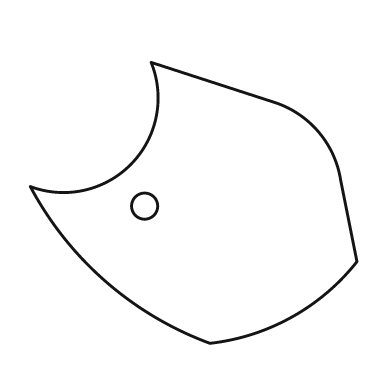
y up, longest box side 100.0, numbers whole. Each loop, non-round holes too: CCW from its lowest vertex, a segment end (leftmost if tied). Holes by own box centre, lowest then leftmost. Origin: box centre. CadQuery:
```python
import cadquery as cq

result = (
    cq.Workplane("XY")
    .moveTo(5.0, -43.0)
    .threePointArc((30.0, -35.0), (50.0, -18.0))
    .lineTo(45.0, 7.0)
    .threePointArc((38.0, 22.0), (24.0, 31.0))
    .lineTo(-13.0, 43.0)
    .threePointArc((-19.0, 12.0), (-50.0, 5.0))
    .threePointArc((-27.0, -24.0), (5.0, -43.0))
    .close()
    .moveTo(-15.0, -1.0)
    .circle(4.0)
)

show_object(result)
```